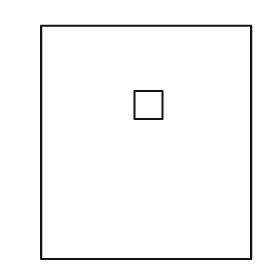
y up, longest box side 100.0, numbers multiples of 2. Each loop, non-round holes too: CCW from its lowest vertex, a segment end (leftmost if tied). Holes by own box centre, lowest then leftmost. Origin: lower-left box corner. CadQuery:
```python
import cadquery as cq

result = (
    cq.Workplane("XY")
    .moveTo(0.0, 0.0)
    .lineTo(90.0, 0.0)
    .lineTo(90.0, 100.0)
    .lineTo(0.0, 100.0)
    .close()
    .moveTo(40.0, 60.0)
    .lineTo(52.0, 60.0)
    .lineTo(52.0, 72.0)
    .lineTo(40.0, 72.0)
    .close()
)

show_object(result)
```